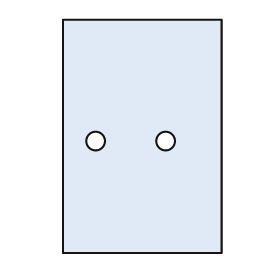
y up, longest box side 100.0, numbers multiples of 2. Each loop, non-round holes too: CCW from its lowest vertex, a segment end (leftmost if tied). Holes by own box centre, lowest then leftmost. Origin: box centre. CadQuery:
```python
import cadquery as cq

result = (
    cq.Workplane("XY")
    .moveTo(-34.0, -50.0)
    .lineTo(34.0, -50.0)
    .lineTo(34.0, 50.0)
    .lineTo(-34.0, 50.0)
    .close()
    .moveTo(-20.0, -2.0)
    .circle(4.0)
    .moveTo(10.0, -2.0)
    .circle(4.0)
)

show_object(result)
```